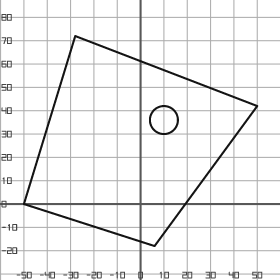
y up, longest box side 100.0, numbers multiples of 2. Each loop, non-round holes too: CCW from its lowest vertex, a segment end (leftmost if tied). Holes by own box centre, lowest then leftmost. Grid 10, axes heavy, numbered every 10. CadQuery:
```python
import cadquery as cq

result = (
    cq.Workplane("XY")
    .moveTo(6.0, -18.0)
    .lineTo(50.0, 42.0)
    .lineTo(-28.0, 72.0)
    .lineTo(-50.0, 0.0)
    .close()
    .moveTo(10.0, 36.0)
    .circle(6.0)
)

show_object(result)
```